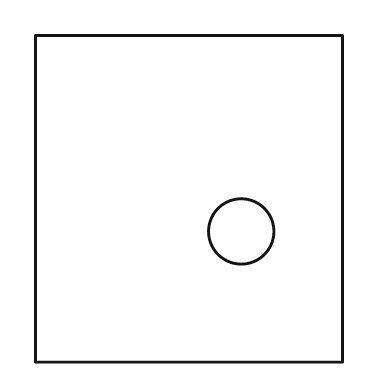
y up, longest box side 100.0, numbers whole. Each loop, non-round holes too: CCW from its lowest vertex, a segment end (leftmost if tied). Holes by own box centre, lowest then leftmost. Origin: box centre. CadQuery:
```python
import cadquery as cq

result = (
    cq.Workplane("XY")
    .moveTo(-47.0, -50.0)
    .lineTo(47.0, -50.0)
    .lineTo(47.0, 50.0)
    .lineTo(-47.0, 50.0)
    .close()
    .moveTo(16.0, -10.0)
    .circle(10.0)
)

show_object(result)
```